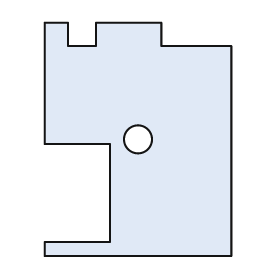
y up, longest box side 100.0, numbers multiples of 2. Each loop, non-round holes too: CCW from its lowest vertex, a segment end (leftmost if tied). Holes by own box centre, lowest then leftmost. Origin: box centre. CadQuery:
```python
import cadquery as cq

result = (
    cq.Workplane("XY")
    .moveTo(-40.0, -50.0)
    .lineTo(40.0, -50.0)
    .lineTo(40.0, 40.0)
    .lineTo(10.0, 40.0)
    .lineTo(10.0, 50.0)
    .lineTo(-18.0, 50.0)
    .lineTo(-18.0, 40.0)
    .lineTo(-30.0, 40.0)
    .lineTo(-30.0, 50.0)
    .lineTo(-40.0, 50.0)
    .lineTo(-40.0, -2.0)
    .lineTo(-12.0, -2.0)
    .lineTo(-12.0, -44.0)
    .lineTo(-40.0, -44.0)
    .close()
    .moveTo(0.0, 0.0)
    .circle(6.0)
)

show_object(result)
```